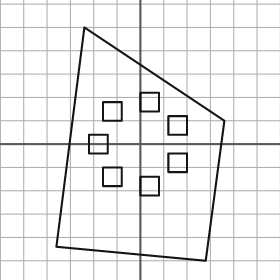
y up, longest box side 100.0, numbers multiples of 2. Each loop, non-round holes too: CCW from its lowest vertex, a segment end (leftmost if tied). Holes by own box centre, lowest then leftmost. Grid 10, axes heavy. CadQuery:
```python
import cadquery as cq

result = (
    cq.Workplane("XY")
    .moveTo(28.0, -50.0)
    .lineTo(36.0, 10.0)
    .lineTo(-24.0, 50.0)
    .lineTo(-36.0, -44.0)
    .close()
    .moveTo(0.0, -22.0)
    .lineTo(8.0, -22.0)
    .lineTo(8.0, -14.0)
    .lineTo(0.0, -14.0)
    .close()
    .moveTo(-16.0, -18.0)
    .lineTo(-8.0, -18.0)
    .lineTo(-8.0, -10.0)
    .lineTo(-16.0, -10.0)
    .close()
    .moveTo(12.0, -12.0)
    .lineTo(20.0, -12.0)
    .lineTo(20.0, -4.0)
    .lineTo(12.0, -4.0)
    .close()
    .moveTo(-22.0, -4.0)
    .lineTo(-14.0, -4.0)
    .lineTo(-14.0, 4.0)
    .lineTo(-22.0, 4.0)
    .close()
    .moveTo(12.0, 4.0)
    .lineTo(20.0, 4.0)
    .lineTo(20.0, 12.0)
    .lineTo(12.0, 12.0)
    .close()
    .moveTo(-16.0, 10.0)
    .lineTo(-8.0, 10.0)
    .lineTo(-8.0, 18.0)
    .lineTo(-16.0, 18.0)
    .close()
    .moveTo(0.0, 14.0)
    .lineTo(8.0, 14.0)
    .lineTo(8.0, 22.0)
    .lineTo(0.0, 22.0)
    .close()
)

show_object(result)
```